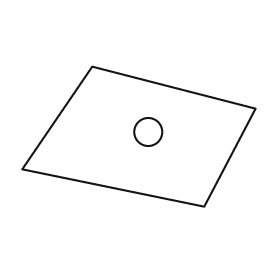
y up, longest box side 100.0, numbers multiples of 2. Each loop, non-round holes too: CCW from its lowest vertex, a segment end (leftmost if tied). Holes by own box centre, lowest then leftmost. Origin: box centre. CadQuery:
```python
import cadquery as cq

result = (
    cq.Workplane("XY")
    .moveTo(28.0, -30.0)
    .lineTo(50.0, 12.0)
    .lineTo(-20.0, 30.0)
    .lineTo(-50.0, -14.0)
    .close()
    .moveTo(4.0, 2.0)
    .circle(6.0)
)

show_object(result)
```